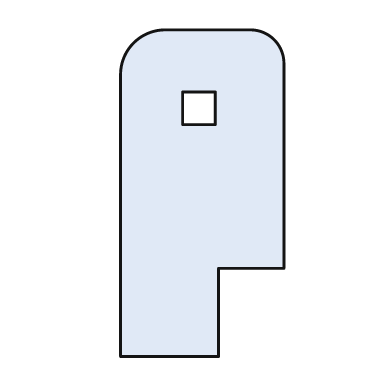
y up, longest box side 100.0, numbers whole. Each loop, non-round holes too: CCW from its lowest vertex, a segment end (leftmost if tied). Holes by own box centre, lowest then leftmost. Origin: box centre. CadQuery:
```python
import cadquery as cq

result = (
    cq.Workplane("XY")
    .moveTo(-25.0, -50.0)
    .lineTo(5.0, -50.0)
    .lineTo(5.0, -23.0)
    .lineTo(25.0, -23.0)
    .lineTo(25.0, 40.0)
    .threePointArc((22.0, 47.0), (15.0, 50.0))
    .lineTo(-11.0, 50.0)
    .threePointArc((-21.0, 46.0), (-25.0, 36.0))
    .close()
    .moveTo(-6.0, 21.0)
    .lineTo(4.0, 21.0)
    .lineTo(4.0, 31.0)
    .lineTo(-6.0, 31.0)
    .close()
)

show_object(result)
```